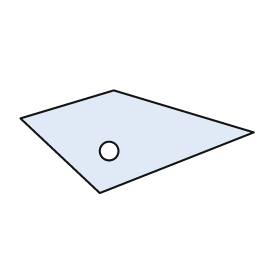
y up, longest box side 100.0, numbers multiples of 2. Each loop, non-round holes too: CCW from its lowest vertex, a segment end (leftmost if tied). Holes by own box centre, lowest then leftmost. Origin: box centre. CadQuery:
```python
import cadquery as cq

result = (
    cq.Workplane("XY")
    .moveTo(-16.0, -22.0)
    .lineTo(50.0, 4.0)
    .lineTo(-10.0, 22.0)
    .lineTo(-50.0, 10.0)
    .close()
    .moveTo(-12.0, -4.0)
    .circle(4.0)
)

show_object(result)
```